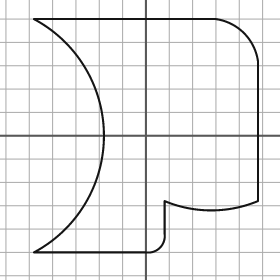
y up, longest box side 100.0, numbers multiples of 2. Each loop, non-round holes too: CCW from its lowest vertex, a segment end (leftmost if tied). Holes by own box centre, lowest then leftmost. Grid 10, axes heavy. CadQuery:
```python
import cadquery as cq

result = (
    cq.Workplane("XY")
    .moveTo(-48.0, -50.0)
    .lineTo(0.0, -50.0)
    .threePointArc((6.0, -48.0), (8.0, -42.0))
    .lineTo(8.0, -28.0)
    .threePointArc((28.0, -32.0), (48.0, -28.0))
    .lineTo(48.0, 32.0)
    .threePointArc((42.0, 44.0), (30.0, 50.0))
    .lineTo(-48.0, 50.0)
    .threePointArc((-18.0, 0.0), (-48.0, -50.0))
    .close()
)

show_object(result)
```